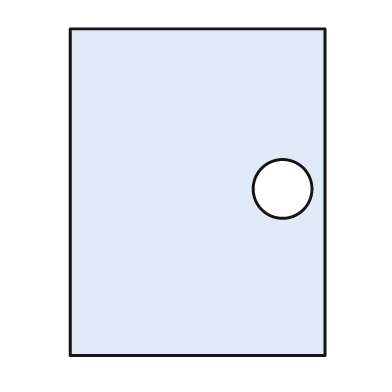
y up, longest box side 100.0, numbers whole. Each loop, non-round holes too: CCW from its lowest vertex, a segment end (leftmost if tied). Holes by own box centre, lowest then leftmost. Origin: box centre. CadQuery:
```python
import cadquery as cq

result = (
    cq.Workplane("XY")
    .moveTo(-39.0, -50.0)
    .lineTo(39.0, -50.0)
    .lineTo(39.0, 50.0)
    .lineTo(-39.0, 50.0)
    .close()
    .moveTo(26.0, 1.0)
    .circle(9.0)
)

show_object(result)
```